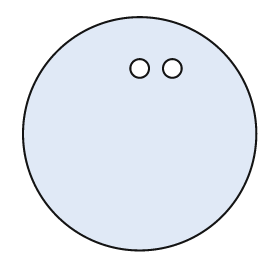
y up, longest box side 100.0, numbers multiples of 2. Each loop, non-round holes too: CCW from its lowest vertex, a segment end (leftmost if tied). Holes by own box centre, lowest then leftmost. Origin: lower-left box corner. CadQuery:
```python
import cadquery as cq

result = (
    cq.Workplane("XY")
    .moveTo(50.0, 50.0)
    .circle(50.0)
    .moveTo(50.0, 78.0)
    .circle(4.0)
    .moveTo(64.0, 78.0)
    .circle(4.0)
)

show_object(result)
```